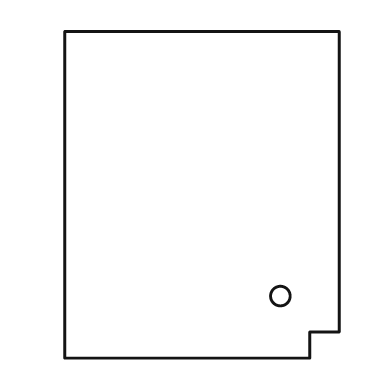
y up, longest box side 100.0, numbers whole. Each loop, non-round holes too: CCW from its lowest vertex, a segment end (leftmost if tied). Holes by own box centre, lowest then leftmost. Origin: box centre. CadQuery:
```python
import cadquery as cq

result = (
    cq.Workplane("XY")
    .moveTo(-42.0, -50.0)
    .lineTo(33.0, -50.0)
    .lineTo(33.0, -42.0)
    .lineTo(42.0, -42.0)
    .lineTo(42.0, 50.0)
    .lineTo(-42.0, 50.0)
    .close()
    .moveTo(24.0, -31.0)
    .circle(3.0)
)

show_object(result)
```